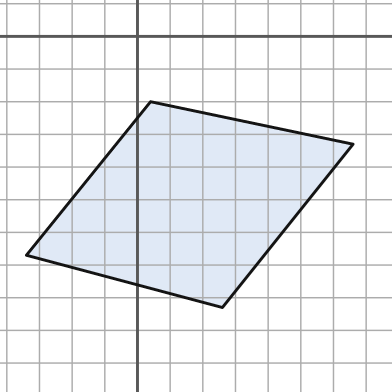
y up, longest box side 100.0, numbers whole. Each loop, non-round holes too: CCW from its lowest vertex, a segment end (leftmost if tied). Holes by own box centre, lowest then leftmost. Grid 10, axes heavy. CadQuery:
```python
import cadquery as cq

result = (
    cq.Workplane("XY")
    .moveTo(26.0, -83.0)
    .lineTo(66.0, -33.0)
    .lineTo(4.0, -20.0)
    .lineTo(-34.0, -67.0)
    .close()
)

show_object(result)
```